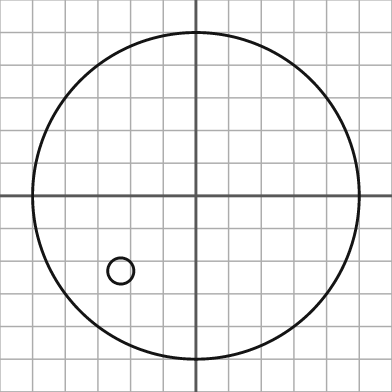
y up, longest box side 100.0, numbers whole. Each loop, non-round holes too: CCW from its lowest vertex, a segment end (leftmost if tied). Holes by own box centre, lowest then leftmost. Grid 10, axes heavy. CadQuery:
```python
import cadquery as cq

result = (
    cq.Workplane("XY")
    .moveTo(0.0, 0.0)
    .circle(50.0)
    .moveTo(-23.0, -23.0)
    .circle(4.0)
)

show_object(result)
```